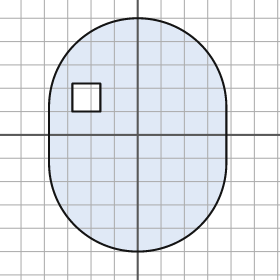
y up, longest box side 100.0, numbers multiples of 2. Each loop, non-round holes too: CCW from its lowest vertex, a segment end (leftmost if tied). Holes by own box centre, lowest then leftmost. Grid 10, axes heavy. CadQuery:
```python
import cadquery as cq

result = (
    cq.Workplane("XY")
    .moveTo(-38.0, -12.0)
    .threePointArc((0.0, -50.0), (38.0, -12.0))
    .lineTo(38.0, 12.0)
    .threePointArc((0.0, 50.0), (-38.0, 12.0))
    .close()
    .moveTo(-28.0, 10.0)
    .lineTo(-16.0, 10.0)
    .lineTo(-16.0, 22.0)
    .lineTo(-28.0, 22.0)
    .close()
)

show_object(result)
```